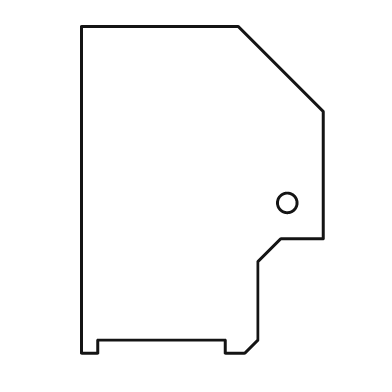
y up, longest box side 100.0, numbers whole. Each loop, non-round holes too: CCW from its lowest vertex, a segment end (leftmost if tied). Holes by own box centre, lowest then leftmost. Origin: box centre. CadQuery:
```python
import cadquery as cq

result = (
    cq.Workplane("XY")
    .moveTo(-37.0, -50.0)
    .lineTo(-32.0, -50.0)
    .lineTo(-32.0, -46.0)
    .lineTo(7.0, -46.0)
    .lineTo(7.0, -50.0)
    .lineTo(13.0, -50.0)
    .lineTo(17.0, -46.0)
    .lineTo(17.0, -22.0)
    .lineTo(24.0, -15.0)
    .lineTo(37.0, -15.0)
    .lineTo(37.0, 24.0)
    .lineTo(11.0, 50.0)
    .lineTo(-37.0, 50.0)
    .close()
    .moveTo(26.0, -4.0)
    .circle(3.0)
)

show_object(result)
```